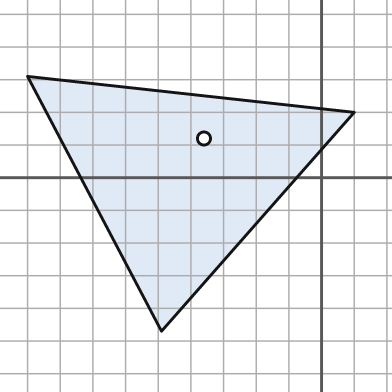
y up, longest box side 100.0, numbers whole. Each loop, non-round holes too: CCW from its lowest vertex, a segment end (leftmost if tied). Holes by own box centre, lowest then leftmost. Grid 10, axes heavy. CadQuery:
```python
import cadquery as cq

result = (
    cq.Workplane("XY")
    .moveTo(-49.0, -47.0)
    .lineTo(10.0, 20.0)
    .lineTo(-90.0, 31.0)
    .close()
    .moveTo(-36.0, 12.0)
    .circle(2.0)
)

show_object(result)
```